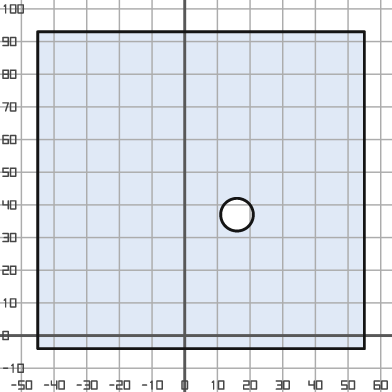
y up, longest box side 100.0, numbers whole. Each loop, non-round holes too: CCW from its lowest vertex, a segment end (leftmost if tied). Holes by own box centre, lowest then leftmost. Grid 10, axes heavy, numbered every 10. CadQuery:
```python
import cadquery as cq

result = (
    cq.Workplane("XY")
    .moveTo(-45.0, -4.0)
    .lineTo(55.0, -4.0)
    .lineTo(55.0, 93.0)
    .lineTo(-45.0, 93.0)
    .close()
    .moveTo(16.0, 37.0)
    .circle(5.0)
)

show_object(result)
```